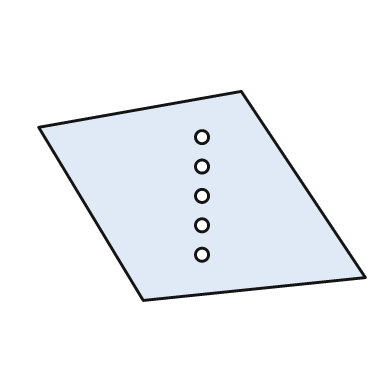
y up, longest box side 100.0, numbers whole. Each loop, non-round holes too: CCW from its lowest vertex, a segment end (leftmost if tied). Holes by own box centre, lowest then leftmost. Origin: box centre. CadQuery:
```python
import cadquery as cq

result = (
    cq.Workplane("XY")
    .moveTo(-18.0, -32.0)
    .lineTo(50.0, -25.0)
    .lineTo(12.0, 32.0)
    .lineTo(-50.0, 21.0)
    .close()
    .moveTo(0.0, -18.0)
    .circle(2.0)
    .moveTo(0.0, -9.0)
    .circle(2.0)
    .moveTo(0.0, 0.0)
    .circle(2.0)
    .moveTo(0.0, 9.0)
    .circle(2.0)
    .moveTo(0.0, 18.0)
    .circle(2.0)
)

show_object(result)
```